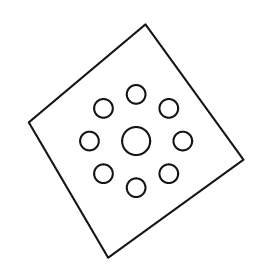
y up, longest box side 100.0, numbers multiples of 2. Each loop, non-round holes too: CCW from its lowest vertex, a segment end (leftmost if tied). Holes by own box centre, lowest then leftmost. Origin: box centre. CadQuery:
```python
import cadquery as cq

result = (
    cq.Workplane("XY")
    .moveTo(-12.0, -50.0)
    .lineTo(46.0, -8.0)
    .lineTo(4.0, 50.0)
    .lineTo(-46.0, 8.0)
    .close()
    .moveTo(0.0, -20.0)
    .circle(4.0)
    .moveTo(-14.0, -14.0)
    .circle(4.0)
    .moveTo(14.0, -14.0)
    .circle(4.0)
    .moveTo(-20.0, 0.0)
    .circle(4.0)
    .moveTo(0.0, 0.0)
    .circle(6.0)
    .moveTo(20.0, 0.0)
    .circle(4.0)
    .moveTo(-14.0, 14.0)
    .circle(4.0)
    .moveTo(14.0, 14.0)
    .circle(4.0)
    .moveTo(0.0, 20.0)
    .circle(4.0)
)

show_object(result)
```